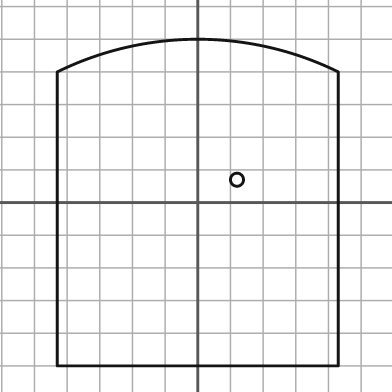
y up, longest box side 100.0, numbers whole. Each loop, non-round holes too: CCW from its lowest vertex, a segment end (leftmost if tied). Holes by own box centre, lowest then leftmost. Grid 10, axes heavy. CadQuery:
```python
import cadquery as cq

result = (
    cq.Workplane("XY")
    .moveTo(-43.0, -50.0)
    .lineTo(43.0, -50.0)
    .lineTo(43.0, 40.0)
    .threePointArc((0.0, 50.0), (-43.0, 40.0))
    .close()
    .moveTo(12.0, 7.0)
    .circle(2.0)
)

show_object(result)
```